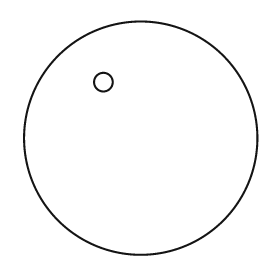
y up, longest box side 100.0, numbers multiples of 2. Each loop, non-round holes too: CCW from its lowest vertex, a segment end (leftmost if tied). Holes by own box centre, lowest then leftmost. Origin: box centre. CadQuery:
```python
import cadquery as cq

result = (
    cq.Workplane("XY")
    .moveTo(0.0, 0.0)
    .circle(50.0)
    .moveTo(-16.0, 24.0)
    .circle(4.0)
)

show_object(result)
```